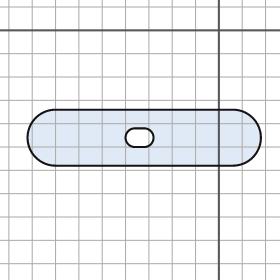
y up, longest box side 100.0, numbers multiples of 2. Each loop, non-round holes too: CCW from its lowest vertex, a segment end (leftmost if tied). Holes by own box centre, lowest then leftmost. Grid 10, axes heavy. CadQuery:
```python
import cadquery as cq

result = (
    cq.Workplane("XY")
    .moveTo(-70.0, -58.0)
    .lineTo(6.0, -58.0)
    .threePointArc((18.0, -46.0), (6.0, -34.0))
    .lineTo(-70.0, -34.0)
    .threePointArc((-82.0, -46.0), (-70.0, -58.0))
    .close()
    .moveTo(-36.0, -50.0)
    .lineTo(-32.0, -50.0)
    .threePointArc((-28.0, -46.0), (-32.0, -42.0))
    .lineTo(-36.0, -42.0)
    .threePointArc((-40.0, -46.0), (-36.0, -50.0))
    .close()
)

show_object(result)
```